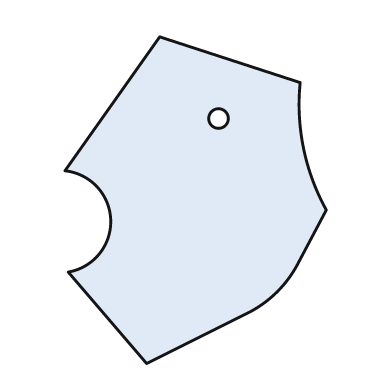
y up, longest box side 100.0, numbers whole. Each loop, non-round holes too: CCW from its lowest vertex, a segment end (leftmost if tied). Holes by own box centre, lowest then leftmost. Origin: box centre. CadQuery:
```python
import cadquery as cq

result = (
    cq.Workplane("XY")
    .moveTo(-15.0, -50.0)
    .lineTo(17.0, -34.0)
    .threePointArc((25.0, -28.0), (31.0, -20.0))
    .lineTo(40.0, -3.0)
    .threePointArc((33.0, 16.0), (32.0, 36.0))
    .lineTo(-11.0, 50.0)
    .lineTo(-40.0, 9.0)
    .threePointArc((-26.0, -6.0), (-39.0, -22.0))
    .close()
    .moveTo(7.0, 25.0)
    .circle(3.0)
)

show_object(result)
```